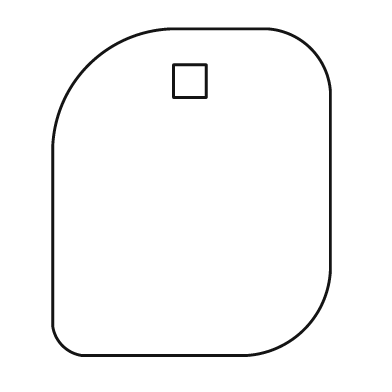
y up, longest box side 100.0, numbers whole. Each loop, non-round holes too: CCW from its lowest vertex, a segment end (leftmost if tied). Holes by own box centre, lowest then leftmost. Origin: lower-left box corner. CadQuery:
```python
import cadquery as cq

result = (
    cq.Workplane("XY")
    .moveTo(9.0, 0.0)
    .lineTo(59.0, 0.0)
    .threePointArc((77.0, 8.0), (85.0, 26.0))
    .lineTo(85.0, 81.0)
    .threePointArc((79.0, 94.0), (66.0, 100.0))
    .lineTo(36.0, 100.0)
    .threePointArc((11.0, 89.0), (0.0, 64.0))
    .lineTo(0.0, 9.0)
    .threePointArc((3.0, 3.0), (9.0, 0.0))
    .close()
    .moveTo(37.0, 79.0)
    .lineTo(47.0, 79.0)
    .lineTo(47.0, 89.0)
    .lineTo(37.0, 89.0)
    .close()
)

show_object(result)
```